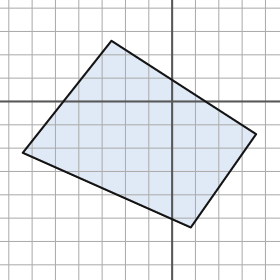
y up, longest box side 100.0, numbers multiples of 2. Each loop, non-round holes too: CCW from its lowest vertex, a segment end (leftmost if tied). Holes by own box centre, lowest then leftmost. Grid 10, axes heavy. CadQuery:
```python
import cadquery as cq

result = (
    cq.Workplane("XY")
    .moveTo(8.0, -54.0)
    .lineTo(36.0, -14.0)
    .lineTo(-26.0, 26.0)
    .lineTo(-64.0, -22.0)
    .close()
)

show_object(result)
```